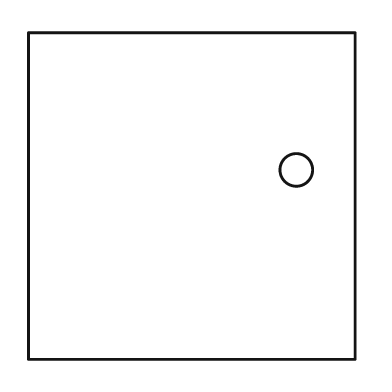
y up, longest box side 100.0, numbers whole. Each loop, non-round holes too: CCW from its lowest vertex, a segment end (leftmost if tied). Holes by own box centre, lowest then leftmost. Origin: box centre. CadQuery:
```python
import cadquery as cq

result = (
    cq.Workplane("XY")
    .moveTo(-50.0, -50.0)
    .lineTo(50.0, -50.0)
    .lineTo(50.0, 50.0)
    .lineTo(-50.0, 50.0)
    .close()
    .moveTo(32.0, 8.0)
    .circle(5.0)
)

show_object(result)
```